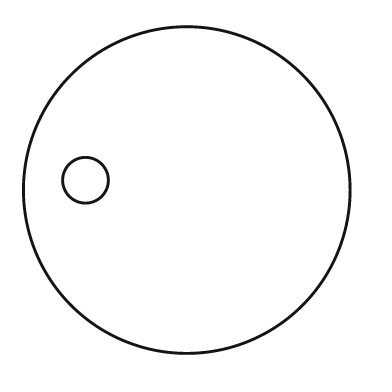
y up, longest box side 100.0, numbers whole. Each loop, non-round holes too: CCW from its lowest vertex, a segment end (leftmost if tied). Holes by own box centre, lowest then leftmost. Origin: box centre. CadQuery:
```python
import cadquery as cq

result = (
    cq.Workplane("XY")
    .moveTo(0.0, 0.0)
    .circle(50.0)
    .moveTo(-31.0, 3.0)
    .circle(7.0)
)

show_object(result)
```